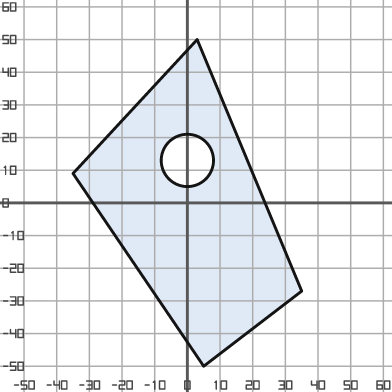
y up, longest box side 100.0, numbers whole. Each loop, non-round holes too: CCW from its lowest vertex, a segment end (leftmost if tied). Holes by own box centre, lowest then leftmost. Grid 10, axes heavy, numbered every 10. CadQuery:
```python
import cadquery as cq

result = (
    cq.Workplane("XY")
    .moveTo(5.0, -50.0)
    .lineTo(35.0, -27.0)
    .lineTo(3.0, 50.0)
    .lineTo(-35.0, 9.0)
    .close()
    .moveTo(0.0, 13.0)
    .circle(8.0)
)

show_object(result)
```